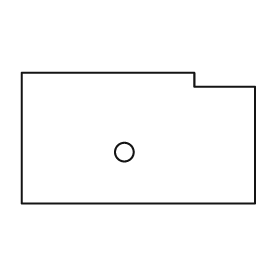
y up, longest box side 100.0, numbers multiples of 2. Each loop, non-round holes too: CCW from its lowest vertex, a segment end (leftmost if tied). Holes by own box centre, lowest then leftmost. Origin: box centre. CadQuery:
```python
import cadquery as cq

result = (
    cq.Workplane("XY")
    .moveTo(-50.0, -28.0)
    .lineTo(50.0, -28.0)
    .lineTo(50.0, 22.0)
    .lineTo(24.0, 22.0)
    .lineTo(24.0, 28.0)
    .lineTo(-50.0, 28.0)
    .close()
    .moveTo(-6.0, -6.0)
    .circle(4.0)
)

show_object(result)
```